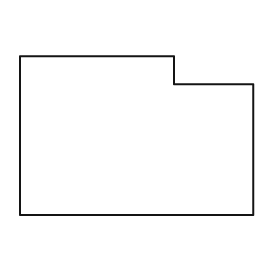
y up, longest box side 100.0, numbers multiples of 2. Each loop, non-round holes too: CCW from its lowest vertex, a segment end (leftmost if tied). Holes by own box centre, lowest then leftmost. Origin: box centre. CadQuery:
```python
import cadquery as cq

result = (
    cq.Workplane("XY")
    .moveTo(-50.0, -34.0)
    .lineTo(50.0, -34.0)
    .lineTo(50.0, 22.0)
    .lineTo(16.0, 22.0)
    .lineTo(16.0, 34.0)
    .lineTo(-50.0, 34.0)
    .close()
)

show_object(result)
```